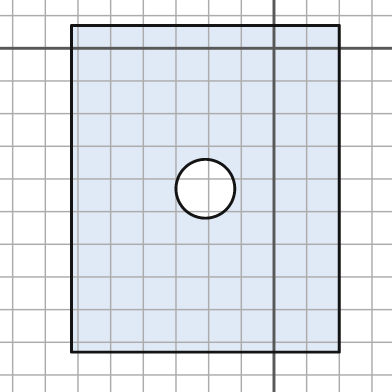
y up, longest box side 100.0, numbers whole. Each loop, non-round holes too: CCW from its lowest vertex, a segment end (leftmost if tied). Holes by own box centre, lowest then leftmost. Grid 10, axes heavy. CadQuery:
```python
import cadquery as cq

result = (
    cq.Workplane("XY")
    .moveTo(-62.0, -93.0)
    .lineTo(20.0, -93.0)
    .lineTo(20.0, 7.0)
    .lineTo(-62.0, 7.0)
    .close()
    .moveTo(-21.0, -43.0)
    .circle(9.0)
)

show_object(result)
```